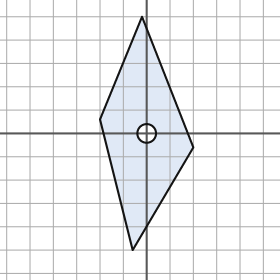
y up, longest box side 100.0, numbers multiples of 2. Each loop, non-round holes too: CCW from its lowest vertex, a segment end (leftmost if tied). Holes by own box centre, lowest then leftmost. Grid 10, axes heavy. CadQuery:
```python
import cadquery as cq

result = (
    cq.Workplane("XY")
    .moveTo(-6.0, -50.0)
    .lineTo(20.0, -6.0)
    .lineTo(-2.0, 50.0)
    .lineTo(-20.0, 6.0)
    .close()
    .moveTo(0.0, 0.0)
    .circle(4.0)
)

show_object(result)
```